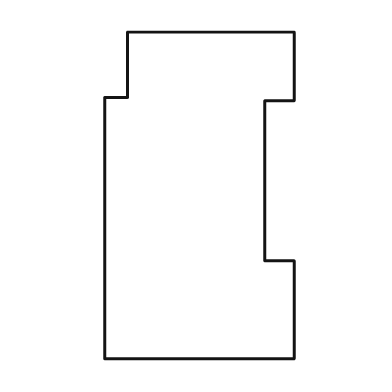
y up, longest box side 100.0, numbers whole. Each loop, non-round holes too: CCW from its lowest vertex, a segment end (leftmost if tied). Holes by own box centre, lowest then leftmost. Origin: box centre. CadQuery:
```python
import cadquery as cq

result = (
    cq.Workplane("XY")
    .moveTo(-29.0, -50.0)
    .lineTo(29.0, -50.0)
    .lineTo(29.0, -20.0)
    .lineTo(20.0, -20.0)
    .lineTo(20.0, 29.0)
    .lineTo(29.0, 29.0)
    .lineTo(29.0, 50.0)
    .lineTo(-22.0, 50.0)
    .lineTo(-22.0, 30.0)
    .lineTo(-29.0, 30.0)
    .close()
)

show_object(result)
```